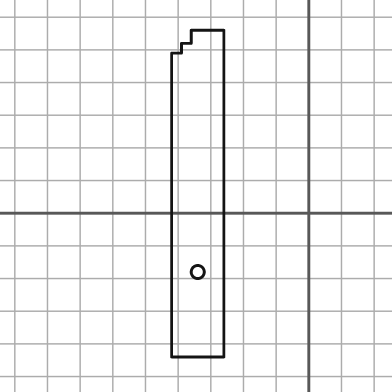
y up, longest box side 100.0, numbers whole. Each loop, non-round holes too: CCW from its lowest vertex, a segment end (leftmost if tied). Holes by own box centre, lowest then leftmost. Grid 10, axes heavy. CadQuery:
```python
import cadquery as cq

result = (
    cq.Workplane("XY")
    .moveTo(-42.0, -44.0)
    .lineTo(-26.0, -44.0)
    .lineTo(-26.0, 56.0)
    .lineTo(-36.0, 56.0)
    .lineTo(-36.0, 52.0)
    .lineTo(-39.0, 52.0)
    .lineTo(-39.0, 49.0)
    .lineTo(-42.0, 49.0)
    .close()
    .moveTo(-34.0, -18.0)
    .circle(2.0)
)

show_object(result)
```